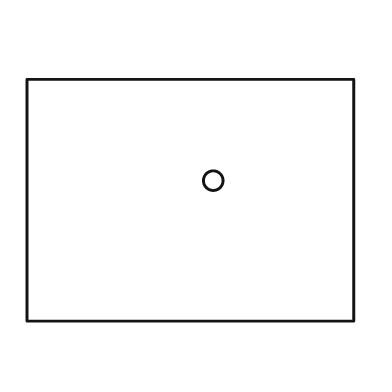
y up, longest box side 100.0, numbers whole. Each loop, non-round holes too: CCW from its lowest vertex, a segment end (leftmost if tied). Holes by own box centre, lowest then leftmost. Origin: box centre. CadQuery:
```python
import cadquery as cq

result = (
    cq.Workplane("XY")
    .moveTo(-50.0, -37.0)
    .lineTo(50.0, -37.0)
    .lineTo(50.0, 37.0)
    .lineTo(-50.0, 37.0)
    .close()
    .moveTo(7.0, 6.0)
    .circle(3.0)
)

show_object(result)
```